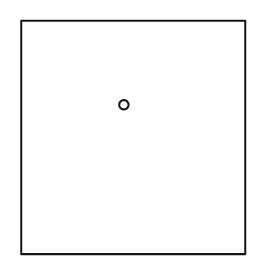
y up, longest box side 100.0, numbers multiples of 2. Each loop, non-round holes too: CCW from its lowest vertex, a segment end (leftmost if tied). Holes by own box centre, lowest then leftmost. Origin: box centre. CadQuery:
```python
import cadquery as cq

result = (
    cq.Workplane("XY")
    .moveTo(-48.0, -50.0)
    .lineTo(48.0, -50.0)
    .lineTo(48.0, 50.0)
    .lineTo(-48.0, 50.0)
    .close()
    .moveTo(-4.0, 14.0)
    .circle(2.0)
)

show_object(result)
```